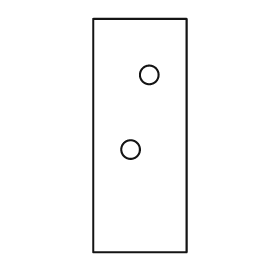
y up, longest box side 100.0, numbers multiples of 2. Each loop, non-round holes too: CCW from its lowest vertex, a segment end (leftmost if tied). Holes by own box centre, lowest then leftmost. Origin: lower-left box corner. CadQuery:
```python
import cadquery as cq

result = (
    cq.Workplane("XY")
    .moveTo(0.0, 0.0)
    .lineTo(40.0, 0.0)
    .lineTo(40.0, 100.0)
    .lineTo(0.0, 100.0)
    .close()
    .moveTo(16.0, 44.0)
    .circle(4.0)
    .moveTo(24.0, 76.0)
    .circle(4.0)
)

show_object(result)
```